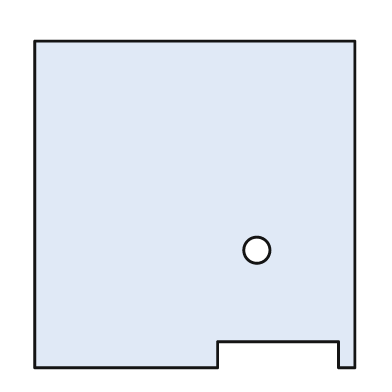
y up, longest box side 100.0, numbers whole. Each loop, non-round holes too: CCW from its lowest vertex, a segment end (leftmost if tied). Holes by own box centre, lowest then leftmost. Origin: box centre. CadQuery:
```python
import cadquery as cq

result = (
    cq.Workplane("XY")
    .moveTo(-49.0, -50.0)
    .lineTo(7.0, -50.0)
    .lineTo(7.0, -42.0)
    .lineTo(44.0, -42.0)
    .lineTo(44.0, -50.0)
    .lineTo(49.0, -50.0)
    .lineTo(49.0, 50.0)
    .lineTo(-49.0, 50.0)
    .close()
    .moveTo(19.0, -14.0)
    .circle(4.0)
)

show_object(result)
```